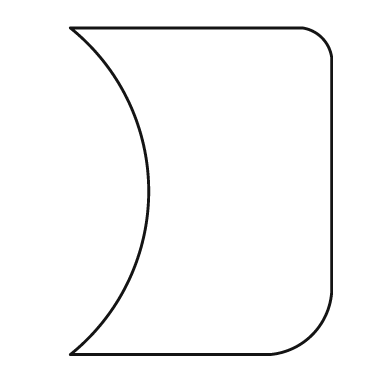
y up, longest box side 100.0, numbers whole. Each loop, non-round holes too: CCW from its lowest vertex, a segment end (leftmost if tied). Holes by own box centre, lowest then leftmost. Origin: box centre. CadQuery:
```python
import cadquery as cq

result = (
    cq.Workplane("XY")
    .moveTo(-40.0, -50.0)
    .lineTo(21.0, -50.0)
    .threePointArc((34.0, -44.0), (40.0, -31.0))
    .lineTo(40.0, 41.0)
    .threePointArc((37.0, 47.0), (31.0, 50.0))
    .lineTo(-40.0, 50.0)
    .threePointArc((-16.0, 0.0), (-40.0, -50.0))
    .close()
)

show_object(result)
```